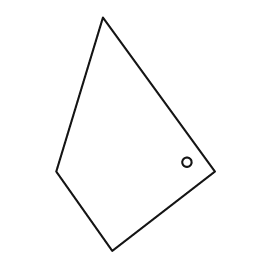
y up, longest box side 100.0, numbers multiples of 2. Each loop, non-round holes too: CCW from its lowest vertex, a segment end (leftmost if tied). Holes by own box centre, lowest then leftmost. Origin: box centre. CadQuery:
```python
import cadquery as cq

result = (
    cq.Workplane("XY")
    .moveTo(-10.0, -50.0)
    .lineTo(34.0, -16.0)
    .lineTo(-14.0, 50.0)
    .lineTo(-34.0, -16.0)
    .close()
    .moveTo(22.0, -12.0)
    .circle(2.0)
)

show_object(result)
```